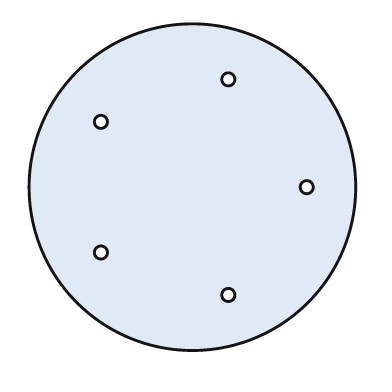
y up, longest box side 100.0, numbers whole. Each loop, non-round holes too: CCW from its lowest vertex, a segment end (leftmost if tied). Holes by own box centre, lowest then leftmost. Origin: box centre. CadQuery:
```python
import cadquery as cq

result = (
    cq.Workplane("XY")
    .moveTo(0.0, 0.0)
    .circle(50.0)
    .moveTo(11.0, -33.0)
    .circle(2.0)
    .moveTo(-28.0, -20.0)
    .circle(2.0)
    .moveTo(35.0, 0.0)
    .circle(2.0)
    .moveTo(-28.0, 20.0)
    .circle(2.0)
    .moveTo(11.0, 33.0)
    .circle(2.0)
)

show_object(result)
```